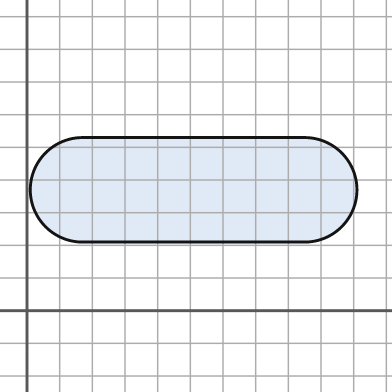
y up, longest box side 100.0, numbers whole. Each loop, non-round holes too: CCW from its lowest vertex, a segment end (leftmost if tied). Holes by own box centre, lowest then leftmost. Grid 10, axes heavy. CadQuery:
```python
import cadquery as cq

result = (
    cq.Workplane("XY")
    .moveTo(17.0, 21.0)
    .lineTo(85.0, 21.0)
    .threePointArc((101.0, 37.0), (85.0, 53.0))
    .lineTo(17.0, 53.0)
    .threePointArc((1.0, 37.0), (17.0, 21.0))
    .close()
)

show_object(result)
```